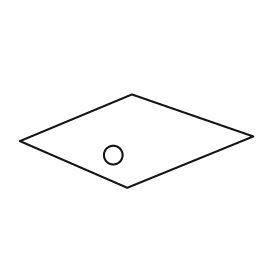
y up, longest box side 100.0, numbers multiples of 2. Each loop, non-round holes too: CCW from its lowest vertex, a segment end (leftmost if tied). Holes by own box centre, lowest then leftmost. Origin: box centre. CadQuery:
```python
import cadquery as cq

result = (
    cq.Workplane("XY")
    .moveTo(-4.0, -20.0)
    .lineTo(50.0, 2.0)
    .lineTo(-2.0, 20.0)
    .lineTo(-50.0, 0.0)
    .close()
    .moveTo(-10.0, -6.0)
    .circle(4.0)
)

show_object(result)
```